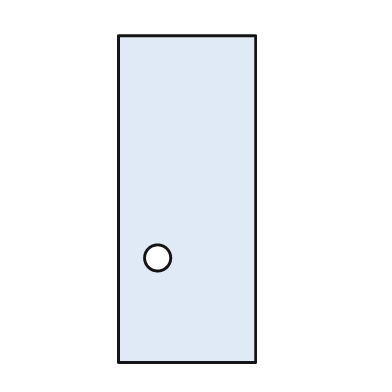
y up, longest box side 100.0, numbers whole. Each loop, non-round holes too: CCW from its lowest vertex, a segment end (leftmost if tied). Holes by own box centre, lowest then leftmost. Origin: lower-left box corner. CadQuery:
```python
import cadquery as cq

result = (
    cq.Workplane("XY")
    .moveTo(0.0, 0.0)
    .lineTo(42.0, 0.0)
    .lineTo(42.0, 100.0)
    .lineTo(0.0, 100.0)
    .close()
    .moveTo(12.0, 32.0)
    .circle(4.0)
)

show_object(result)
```